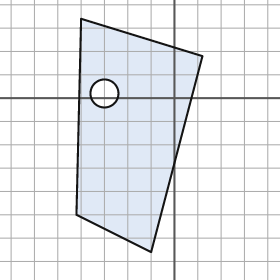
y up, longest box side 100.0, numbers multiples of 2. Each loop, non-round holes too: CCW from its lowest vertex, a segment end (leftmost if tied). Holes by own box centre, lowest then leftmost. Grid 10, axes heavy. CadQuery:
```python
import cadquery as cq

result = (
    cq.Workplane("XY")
    .moveTo(-10.0, -66.0)
    .lineTo(12.0, 18.0)
    .lineTo(-40.0, 34.0)
    .lineTo(-42.0, -50.0)
    .close()
    .moveTo(-30.0, 2.0)
    .circle(6.0)
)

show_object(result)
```